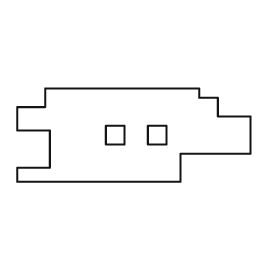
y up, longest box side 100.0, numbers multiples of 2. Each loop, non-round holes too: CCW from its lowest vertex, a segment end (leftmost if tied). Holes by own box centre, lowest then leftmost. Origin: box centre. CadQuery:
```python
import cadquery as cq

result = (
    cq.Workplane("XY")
    .moveTo(-50.0, -20.0)
    .lineTo(20.0, -20.0)
    .lineTo(20.0, -8.0)
    .lineTo(50.0, -8.0)
    .lineTo(50.0, 8.0)
    .lineTo(36.0, 8.0)
    .lineTo(36.0, 16.0)
    .lineTo(28.0, 16.0)
    .lineTo(28.0, 20.0)
    .lineTo(-38.0, 20.0)
    .lineTo(-38.0, 12.0)
    .lineTo(-50.0, 12.0)
    .lineTo(-50.0, 2.0)
    .lineTo(-36.0, 2.0)
    .lineTo(-36.0, -14.0)
    .lineTo(-50.0, -14.0)
    .close()
    .moveTo(-12.0, -4.0)
    .lineTo(-4.0, -4.0)
    .lineTo(-4.0, 4.0)
    .lineTo(-12.0, 4.0)
    .close()
    .moveTo(6.0, -4.0)
    .lineTo(14.0, -4.0)
    .lineTo(14.0, 4.0)
    .lineTo(6.0, 4.0)
    .close()
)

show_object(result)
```